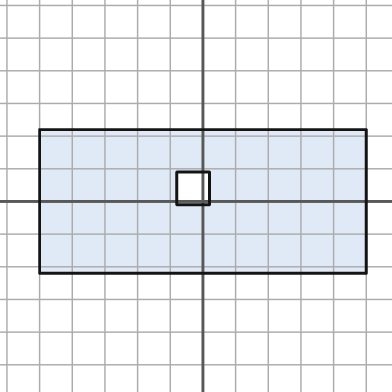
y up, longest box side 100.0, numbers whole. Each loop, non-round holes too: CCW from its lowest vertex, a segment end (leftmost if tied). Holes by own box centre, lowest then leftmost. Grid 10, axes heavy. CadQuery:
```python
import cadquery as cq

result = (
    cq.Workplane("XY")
    .moveTo(-50.0, -22.0)
    .lineTo(50.0, -22.0)
    .lineTo(50.0, 22.0)
    .lineTo(-50.0, 22.0)
    .close()
    .moveTo(-8.0, -1.0)
    .lineTo(2.0, -1.0)
    .lineTo(2.0, 9.0)
    .lineTo(-8.0, 9.0)
    .close()
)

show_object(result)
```